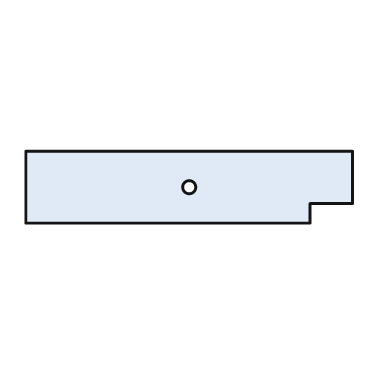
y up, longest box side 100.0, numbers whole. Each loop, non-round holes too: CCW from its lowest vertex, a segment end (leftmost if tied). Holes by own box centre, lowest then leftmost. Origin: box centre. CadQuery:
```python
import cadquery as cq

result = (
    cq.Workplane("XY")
    .moveTo(-50.0, -11.0)
    .lineTo(37.0, -11.0)
    .lineTo(37.0, -5.0)
    .lineTo(50.0, -5.0)
    .lineTo(50.0, 11.0)
    .lineTo(-50.0, 11.0)
    .close()
    .moveTo(0.0, 0.0)
    .circle(2.0)
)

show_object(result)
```